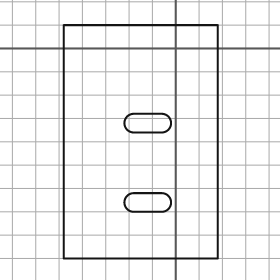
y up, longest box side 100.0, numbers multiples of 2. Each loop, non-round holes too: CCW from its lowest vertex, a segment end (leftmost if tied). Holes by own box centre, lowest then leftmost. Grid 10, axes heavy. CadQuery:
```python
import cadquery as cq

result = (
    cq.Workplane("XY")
    .moveTo(-48.0, -90.0)
    .lineTo(18.0, -90.0)
    .lineTo(18.0, 10.0)
    .lineTo(-48.0, 10.0)
    .close()
    .moveTo(-18.0, -70.0)
    .lineTo(-6.0, -70.0)
    .threePointArc((-2.0, -66.0), (-6.0, -62.0))
    .lineTo(-18.0, -62.0)
    .threePointArc((-22.0, -66.0), (-18.0, -70.0))
    .close()
    .moveTo(-18.0, -36.0)
    .lineTo(-6.0, -36.0)
    .threePointArc((-2.0, -32.0), (-6.0, -28.0))
    .lineTo(-18.0, -28.0)
    .threePointArc((-22.0, -32.0), (-18.0, -36.0))
    .close()
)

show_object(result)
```